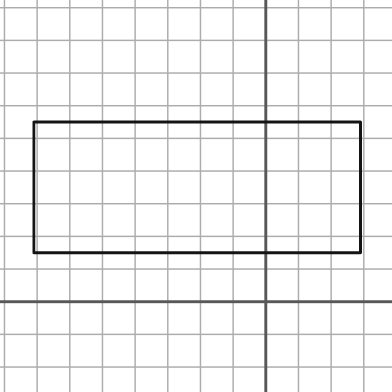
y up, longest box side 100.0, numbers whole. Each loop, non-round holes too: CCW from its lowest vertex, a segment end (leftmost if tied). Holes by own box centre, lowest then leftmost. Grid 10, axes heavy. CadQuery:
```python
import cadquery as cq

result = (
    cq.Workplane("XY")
    .moveTo(-71.0, 15.0)
    .lineTo(29.0, 15.0)
    .lineTo(29.0, 55.0)
    .lineTo(-71.0, 55.0)
    .close()
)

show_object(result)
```